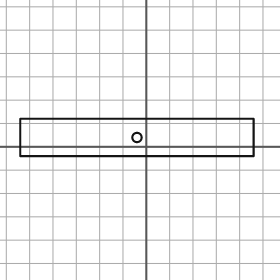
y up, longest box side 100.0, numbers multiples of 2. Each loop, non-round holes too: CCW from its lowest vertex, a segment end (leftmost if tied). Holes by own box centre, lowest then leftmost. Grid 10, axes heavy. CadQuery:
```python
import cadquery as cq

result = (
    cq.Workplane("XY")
    .moveTo(-54.0, -4.0)
    .lineTo(46.0, -4.0)
    .lineTo(46.0, 12.0)
    .lineTo(-54.0, 12.0)
    .close()
    .moveTo(-4.0, 4.0)
    .circle(2.0)
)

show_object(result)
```